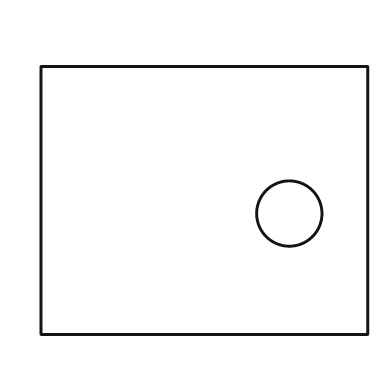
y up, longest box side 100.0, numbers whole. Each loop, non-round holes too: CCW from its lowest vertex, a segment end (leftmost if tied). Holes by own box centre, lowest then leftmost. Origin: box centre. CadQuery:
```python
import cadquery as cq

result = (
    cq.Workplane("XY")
    .moveTo(-50.0, -41.0)
    .lineTo(50.0, -41.0)
    .lineTo(50.0, 41.0)
    .lineTo(-50.0, 41.0)
    .close()
    .moveTo(26.0, -4.0)
    .circle(10.0)
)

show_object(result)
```